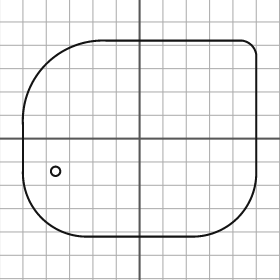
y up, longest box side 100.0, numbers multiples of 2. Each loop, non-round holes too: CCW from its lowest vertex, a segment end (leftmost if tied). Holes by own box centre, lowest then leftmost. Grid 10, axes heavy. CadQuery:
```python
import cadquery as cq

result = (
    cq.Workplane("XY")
    .moveTo(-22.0, -42.0)
    .lineTo(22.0, -42.0)
    .threePointArc((42.0, -34.0), (50.0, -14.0))
    .lineTo(50.0, 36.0)
    .threePointArc((48.0, 40.0), (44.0, 42.0))
    .lineTo(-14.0, 42.0)
    .threePointArc((-40.0, 32.0), (-50.0, 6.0))
    .lineTo(-50.0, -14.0)
    .threePointArc((-42.0, -34.0), (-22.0, -42.0))
    .close()
    .moveTo(-36.0, -14.0)
    .circle(2.0)
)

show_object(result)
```